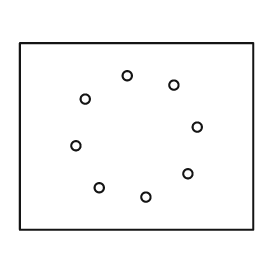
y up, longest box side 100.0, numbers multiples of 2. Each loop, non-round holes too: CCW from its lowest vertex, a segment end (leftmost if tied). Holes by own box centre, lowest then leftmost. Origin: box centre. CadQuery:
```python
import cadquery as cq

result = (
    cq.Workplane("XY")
    .moveTo(-50.0, -40.0)
    .lineTo(50.0, -40.0)
    .lineTo(50.0, 40.0)
    .lineTo(-50.0, 40.0)
    .close()
    .moveTo(4.0, -26.0)
    .circle(2.0)
    .moveTo(-16.0, -22.0)
    .circle(2.0)
    .moveTo(22.0, -16.0)
    .circle(2.0)
    .moveTo(-26.0, -4.0)
    .circle(2.0)
    .moveTo(26.0, 4.0)
    .circle(2.0)
    .moveTo(-22.0, 16.0)
    .circle(2.0)
    .moveTo(16.0, 22.0)
    .circle(2.0)
    .moveTo(-4.0, 26.0)
    .circle(2.0)
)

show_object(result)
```